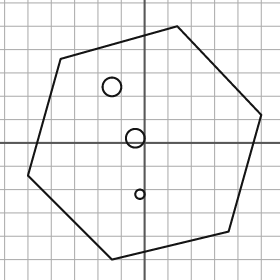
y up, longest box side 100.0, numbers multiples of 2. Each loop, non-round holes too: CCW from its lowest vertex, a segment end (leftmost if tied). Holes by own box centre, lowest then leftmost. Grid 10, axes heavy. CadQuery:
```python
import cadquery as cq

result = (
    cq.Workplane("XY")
    .moveTo(-14.0, -50.0)
    .lineTo(36.0, -38.0)
    .lineTo(50.0, 12.0)
    .lineTo(14.0, 50.0)
    .lineTo(-36.0, 36.0)
    .lineTo(-50.0, -14.0)
    .close()
    .moveTo(-2.0, -22.0)
    .circle(2.0)
    .moveTo(-4.0, 2.0)
    .circle(4.0)
    .moveTo(-14.0, 24.0)
    .circle(4.0)
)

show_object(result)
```